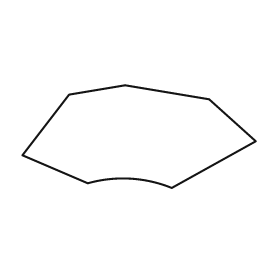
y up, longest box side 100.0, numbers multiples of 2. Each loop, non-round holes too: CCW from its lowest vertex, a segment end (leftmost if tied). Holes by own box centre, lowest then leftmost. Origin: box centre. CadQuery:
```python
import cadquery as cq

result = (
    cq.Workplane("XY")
    .moveTo(14.0, -22.0)
    .lineTo(50.0, -2.0)
    .lineTo(30.0, 16.0)
    .lineTo(-6.0, 22.0)
    .lineTo(-30.0, 18.0)
    .lineTo(-50.0, -8.0)
    .lineTo(-22.0, -20.0)
    .threePointArc((-4.0, -18.0), (14.0, -22.0))
    .close()
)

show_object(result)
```